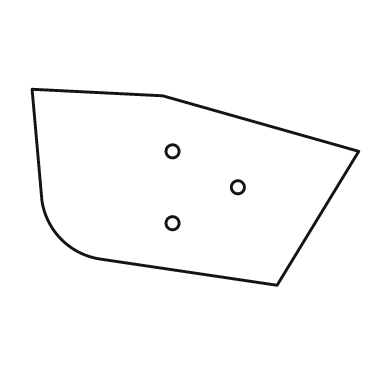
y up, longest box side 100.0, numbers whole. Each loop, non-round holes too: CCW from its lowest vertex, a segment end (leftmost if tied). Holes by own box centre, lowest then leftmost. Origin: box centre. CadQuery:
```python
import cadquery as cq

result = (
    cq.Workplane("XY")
    .moveTo(25.0, -30.0)
    .lineTo(50.0, 11.0)
    .lineTo(-10.0, 28.0)
    .lineTo(-50.0, 30.0)
    .lineTo(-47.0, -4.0)
    .threePointArc((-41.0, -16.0), (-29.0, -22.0))
    .close()
    .moveTo(-7.0, -11.0)
    .circle(2.0)
    .moveTo(13.0, 0.0)
    .circle(2.0)
    .moveTo(-7.0, 11.0)
    .circle(2.0)
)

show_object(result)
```